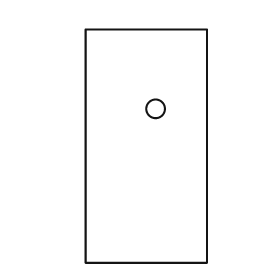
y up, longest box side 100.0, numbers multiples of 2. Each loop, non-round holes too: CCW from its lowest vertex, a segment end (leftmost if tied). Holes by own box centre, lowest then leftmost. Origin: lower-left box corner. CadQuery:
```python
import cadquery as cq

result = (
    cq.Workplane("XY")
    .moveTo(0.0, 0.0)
    .lineTo(52.0, 0.0)
    .lineTo(52.0, 100.0)
    .lineTo(0.0, 100.0)
    .close()
    .moveTo(30.0, 66.0)
    .circle(4.0)
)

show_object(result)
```